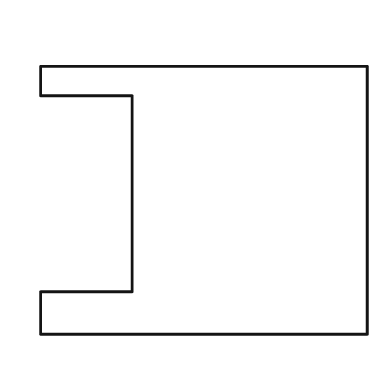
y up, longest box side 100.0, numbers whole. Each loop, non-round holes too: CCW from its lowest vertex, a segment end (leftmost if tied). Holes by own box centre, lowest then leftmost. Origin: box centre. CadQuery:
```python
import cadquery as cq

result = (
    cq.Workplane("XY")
    .moveTo(-50.0, -41.0)
    .lineTo(50.0, -41.0)
    .lineTo(50.0, 41.0)
    .lineTo(-50.0, 41.0)
    .lineTo(-50.0, 32.0)
    .lineTo(-22.0, 32.0)
    .lineTo(-22.0, -28.0)
    .lineTo(-50.0, -28.0)
    .close()
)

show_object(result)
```